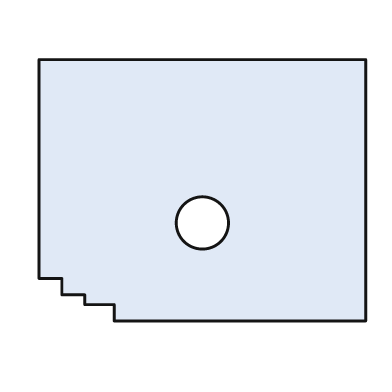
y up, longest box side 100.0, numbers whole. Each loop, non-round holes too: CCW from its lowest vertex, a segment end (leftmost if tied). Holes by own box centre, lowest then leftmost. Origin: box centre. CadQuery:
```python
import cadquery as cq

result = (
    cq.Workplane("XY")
    .moveTo(-27.0, -40.0)
    .lineTo(50.0, -40.0)
    .lineTo(50.0, 40.0)
    .lineTo(-50.0, 40.0)
    .lineTo(-50.0, -27.0)
    .lineTo(-43.0, -27.0)
    .lineTo(-43.0, -32.0)
    .lineTo(-36.0, -32.0)
    .lineTo(-36.0, -35.0)
    .lineTo(-27.0, -35.0)
    .close()
    .moveTo(0.0, -10.0)
    .circle(8.0)
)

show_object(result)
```